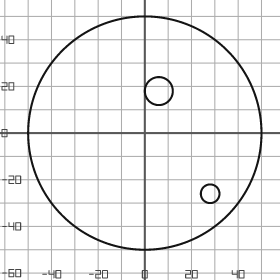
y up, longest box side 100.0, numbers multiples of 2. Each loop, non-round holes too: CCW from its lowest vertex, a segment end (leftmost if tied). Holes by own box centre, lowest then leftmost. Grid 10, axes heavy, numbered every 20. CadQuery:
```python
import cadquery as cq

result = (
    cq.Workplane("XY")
    .moveTo(0.0, 0.0)
    .circle(50.0)
    .moveTo(28.0, -26.0)
    .circle(4.0)
    .moveTo(6.0, 18.0)
    .circle(6.0)
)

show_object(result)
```